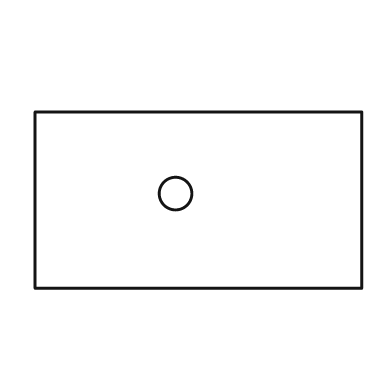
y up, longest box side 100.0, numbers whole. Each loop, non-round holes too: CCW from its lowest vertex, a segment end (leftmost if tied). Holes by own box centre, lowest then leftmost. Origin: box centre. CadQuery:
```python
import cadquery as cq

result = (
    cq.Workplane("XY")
    .moveTo(-50.0, -27.0)
    .lineTo(50.0, -27.0)
    .lineTo(50.0, 27.0)
    .lineTo(-50.0, 27.0)
    .close()
    .moveTo(-7.0, 2.0)
    .circle(5.0)
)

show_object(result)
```